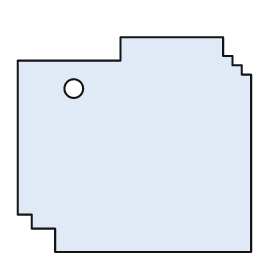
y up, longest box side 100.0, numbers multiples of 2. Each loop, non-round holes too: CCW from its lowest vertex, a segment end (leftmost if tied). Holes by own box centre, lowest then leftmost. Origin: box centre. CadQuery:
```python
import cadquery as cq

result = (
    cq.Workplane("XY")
    .moveTo(-34.0, -46.0)
    .lineTo(50.0, -46.0)
    .lineTo(50.0, 30.0)
    .lineTo(46.0, 30.0)
    .lineTo(46.0, 34.0)
    .lineTo(42.0, 34.0)
    .lineTo(42.0, 38.0)
    .lineTo(38.0, 38.0)
    .lineTo(38.0, 46.0)
    .lineTo(-6.0, 46.0)
    .lineTo(-6.0, 36.0)
    .lineTo(-50.0, 36.0)
    .lineTo(-50.0, -30.0)
    .lineTo(-44.0, -30.0)
    .lineTo(-44.0, -36.0)
    .lineTo(-34.0, -36.0)
    .close()
    .moveTo(-26.0, 24.0)
    .circle(4.0)
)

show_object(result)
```